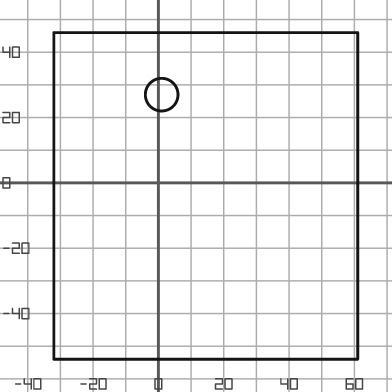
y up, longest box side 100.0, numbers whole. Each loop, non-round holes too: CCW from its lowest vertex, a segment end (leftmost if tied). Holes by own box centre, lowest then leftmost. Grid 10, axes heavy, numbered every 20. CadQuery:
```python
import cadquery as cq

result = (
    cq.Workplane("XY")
    .moveTo(-32.0, -54.0)
    .lineTo(61.0, -54.0)
    .lineTo(61.0, 46.0)
    .lineTo(-32.0, 46.0)
    .close()
    .moveTo(1.0, 27.0)
    .circle(5.0)
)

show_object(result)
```